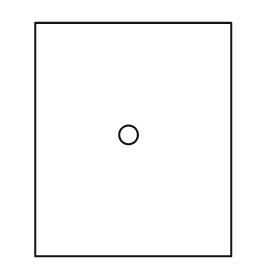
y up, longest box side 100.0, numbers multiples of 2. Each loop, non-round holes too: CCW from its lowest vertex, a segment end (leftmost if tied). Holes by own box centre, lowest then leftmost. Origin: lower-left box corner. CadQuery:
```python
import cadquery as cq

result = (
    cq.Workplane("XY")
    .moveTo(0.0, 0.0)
    .lineTo(84.0, 0.0)
    .lineTo(84.0, 100.0)
    .lineTo(0.0, 100.0)
    .close()
    .moveTo(40.0, 52.0)
    .circle(4.0)
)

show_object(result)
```